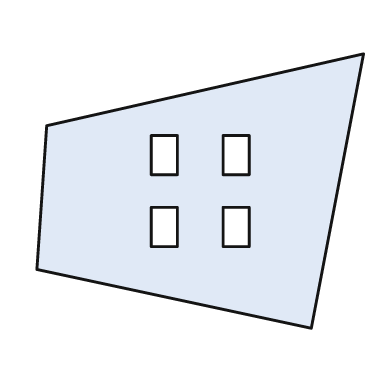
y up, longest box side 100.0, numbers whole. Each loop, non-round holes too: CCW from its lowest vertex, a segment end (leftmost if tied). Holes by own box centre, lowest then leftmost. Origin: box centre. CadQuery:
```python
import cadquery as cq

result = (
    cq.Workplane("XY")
    .moveTo(34.0, -42.0)
    .lineTo(50.0, 42.0)
    .lineTo(-47.0, 20.0)
    .lineTo(-50.0, -24.0)
    .close()
    .moveTo(-15.0, -17.0)
    .lineTo(-7.0, -17.0)
    .lineTo(-7.0, -5.0)
    .lineTo(-15.0, -5.0)
    .close()
    .moveTo(7.0, -17.0)
    .lineTo(15.0, -17.0)
    .lineTo(15.0, -5.0)
    .lineTo(7.0, -5.0)
    .close()
    .moveTo(-15.0, 5.0)
    .lineTo(-7.0, 5.0)
    .lineTo(-7.0, 17.0)
    .lineTo(-15.0, 17.0)
    .close()
    .moveTo(7.0, 5.0)
    .lineTo(15.0, 5.0)
    .lineTo(15.0, 17.0)
    .lineTo(7.0, 17.0)
    .close()
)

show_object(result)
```